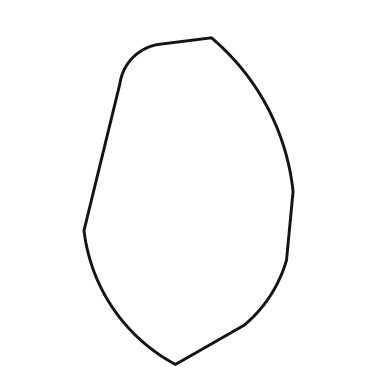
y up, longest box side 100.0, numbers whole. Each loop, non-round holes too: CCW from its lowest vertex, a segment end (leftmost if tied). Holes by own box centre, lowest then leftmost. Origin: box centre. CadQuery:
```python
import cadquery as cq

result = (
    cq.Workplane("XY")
    .moveTo(-4.0, -50.0)
    .lineTo(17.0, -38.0)
    .threePointArc((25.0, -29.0), (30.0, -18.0))
    .lineTo(32.0, 3.0)
    .threePointArc((24.0, 29.0), (7.0, 50.0))
    .lineTo(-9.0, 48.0)
    .threePointArc((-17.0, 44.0), (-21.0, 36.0))
    .lineTo(-32.0, -9.0)
    .threePointArc((-23.0, -33.0), (-4.0, -50.0))
    .close()
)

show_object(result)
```